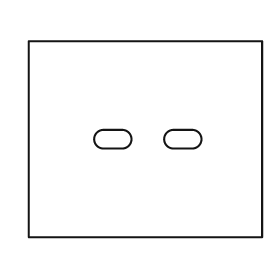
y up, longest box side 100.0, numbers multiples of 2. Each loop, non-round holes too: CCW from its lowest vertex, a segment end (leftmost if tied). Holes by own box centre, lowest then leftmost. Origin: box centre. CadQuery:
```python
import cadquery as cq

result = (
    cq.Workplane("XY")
    .moveTo(-50.0, -42.0)
    .lineTo(50.0, -42.0)
    .lineTo(50.0, 42.0)
    .lineTo(-50.0, 42.0)
    .close()
    .moveTo(-18.0, -4.0)
    .lineTo(-10.0, -4.0)
    .threePointArc((-6.0, 0.0), (-10.0, 4.0))
    .lineTo(-18.0, 4.0)
    .threePointArc((-22.0, 0.0), (-18.0, -4.0))
    .close()
    .moveTo(12.0, -4.0)
    .lineTo(20.0, -4.0)
    .threePointArc((24.0, 0.0), (20.0, 4.0))
    .lineTo(12.0, 4.0)
    .threePointArc((8.0, 0.0), (12.0, -4.0))
    .close()
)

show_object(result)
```